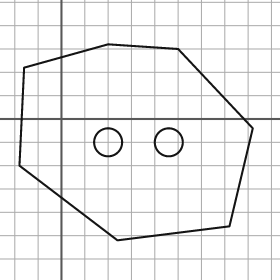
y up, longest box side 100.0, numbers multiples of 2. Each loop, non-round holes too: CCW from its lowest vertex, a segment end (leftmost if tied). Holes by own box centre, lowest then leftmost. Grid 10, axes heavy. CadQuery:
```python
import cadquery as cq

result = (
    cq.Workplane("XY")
    .moveTo(24.0, -52.0)
    .lineTo(72.0, -46.0)
    .lineTo(82.0, -4.0)
    .lineTo(50.0, 30.0)
    .lineTo(20.0, 32.0)
    .lineTo(-16.0, 22.0)
    .lineTo(-18.0, -20.0)
    .close()
    .moveTo(20.0, -10.0)
    .circle(6.0)
    .moveTo(46.0, -10.0)
    .circle(6.0)
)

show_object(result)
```